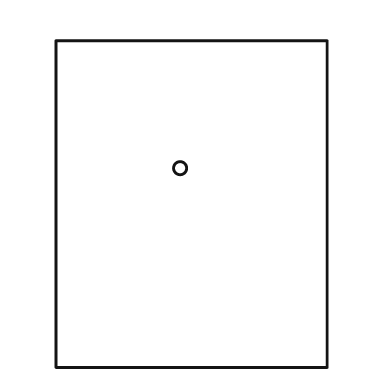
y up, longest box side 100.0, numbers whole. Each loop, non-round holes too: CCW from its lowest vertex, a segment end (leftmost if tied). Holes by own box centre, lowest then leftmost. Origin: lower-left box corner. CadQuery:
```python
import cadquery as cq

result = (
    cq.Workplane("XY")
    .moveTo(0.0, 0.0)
    .lineTo(83.0, 0.0)
    .lineTo(83.0, 100.0)
    .lineTo(0.0, 100.0)
    .close()
    .moveTo(38.0, 61.0)
    .circle(2.0)
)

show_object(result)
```